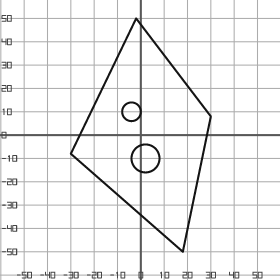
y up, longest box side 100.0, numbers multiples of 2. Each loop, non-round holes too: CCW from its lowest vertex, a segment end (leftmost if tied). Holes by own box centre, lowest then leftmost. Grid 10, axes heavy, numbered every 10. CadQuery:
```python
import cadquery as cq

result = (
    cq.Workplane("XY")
    .moveTo(18.0, -50.0)
    .lineTo(30.0, 8.0)
    .lineTo(-2.0, 50.0)
    .lineTo(-30.0, -8.0)
    .close()
    .moveTo(2.0, -10.0)
    .circle(6.0)
    .moveTo(-4.0, 10.0)
    .circle(4.0)
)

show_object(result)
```